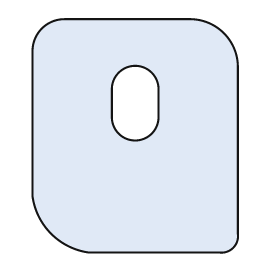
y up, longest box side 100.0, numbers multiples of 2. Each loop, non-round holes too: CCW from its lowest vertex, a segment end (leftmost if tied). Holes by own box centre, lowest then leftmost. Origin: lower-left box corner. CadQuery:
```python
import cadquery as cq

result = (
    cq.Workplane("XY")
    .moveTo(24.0, 0.0)
    .lineTo(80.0, 0.0)
    .threePointArc((86.0, 2.0), (88.0, 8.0))
    .lineTo(88.0, 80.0)
    .threePointArc((82.0, 94.0), (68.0, 100.0))
    .lineTo(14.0, 100.0)
    .threePointArc((4.0, 96.0), (0.0, 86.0))
    .lineTo(0.0, 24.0)
    .threePointArc((8.0, 8.0), (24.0, 0.0))
    .close()
    .moveTo(34.0, 58.0)
    .threePointArc((44.0, 48.0), (54.0, 58.0))
    .lineTo(54.0, 70.0)
    .threePointArc((44.0, 80.0), (34.0, 70.0))
    .close()
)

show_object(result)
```